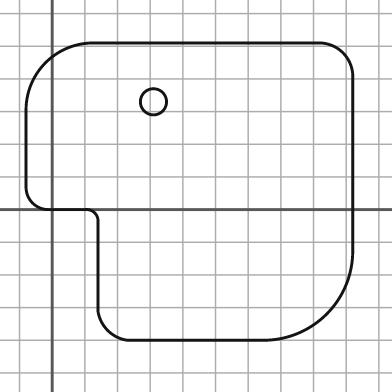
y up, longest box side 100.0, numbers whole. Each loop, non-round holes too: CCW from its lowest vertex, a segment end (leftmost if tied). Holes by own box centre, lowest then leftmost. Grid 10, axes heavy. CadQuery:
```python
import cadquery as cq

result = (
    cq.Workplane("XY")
    .moveTo(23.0, -40.0)
    .lineTo(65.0, -40.0)
    .threePointArc((84.0, -32.0), (92.0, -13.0))
    .lineTo(92.0, 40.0)
    .threePointArc((89.0, 48.0), (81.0, 51.0))
    .lineTo(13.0, 51.0)
    .threePointArc((-2.0, 45.0), (-8.0, 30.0))
    .lineTo(-8.0, 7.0)
    .threePointArc((-6.0, 2.0), (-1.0, 0.0))
    .lineTo(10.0, 0.0)
    .threePointArc((13.0, -1.0), (14.0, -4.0))
    .lineTo(14.0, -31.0)
    .threePointArc((17.0, -37.0), (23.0, -40.0))
    .close()
    .moveTo(31.0, 33.0)
    .circle(4.0)
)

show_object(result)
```